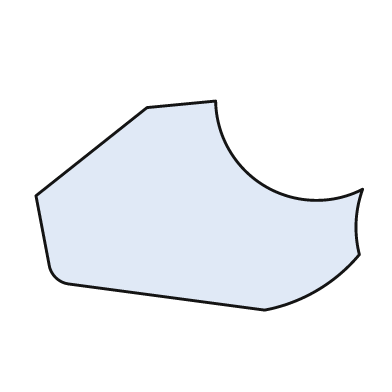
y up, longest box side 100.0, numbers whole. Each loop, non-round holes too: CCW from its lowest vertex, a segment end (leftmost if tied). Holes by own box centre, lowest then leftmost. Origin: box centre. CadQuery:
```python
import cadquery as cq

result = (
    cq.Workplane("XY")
    .moveTo(20.0, -32.0)
    .threePointArc((36.0, -26.0), (49.0, -15.0))
    .threePointArc((48.0, -5.0), (50.0, 5.0))
    .threePointArc((20.0, 6.0), (5.0, 32.0))
    .lineTo(-16.0, 30.0)
    .lineTo(-50.0, 3.0)
    .lineTo(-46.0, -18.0)
    .threePointArc((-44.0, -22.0), (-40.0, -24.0))
    .close()
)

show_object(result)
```